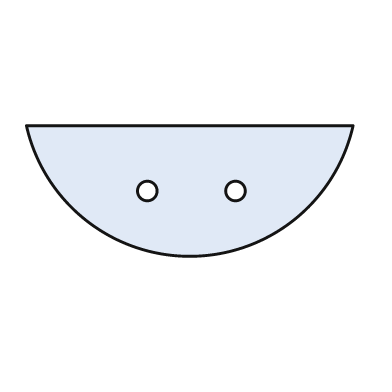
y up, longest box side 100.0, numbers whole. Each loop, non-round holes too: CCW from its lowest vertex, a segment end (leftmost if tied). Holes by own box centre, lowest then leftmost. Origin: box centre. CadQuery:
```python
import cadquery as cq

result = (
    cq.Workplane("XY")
    .moveTo(-50.0, 20.0)
    .threePointArc((0.0, -20.0), (50.0, 20.0))
    .close()
    .moveTo(-13.0, 0.0)
    .circle(3.0)
    .moveTo(14.0, 0.0)
    .circle(3.0)
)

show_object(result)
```